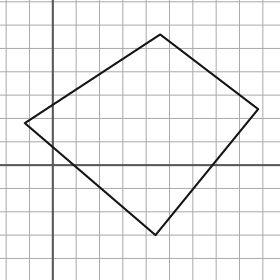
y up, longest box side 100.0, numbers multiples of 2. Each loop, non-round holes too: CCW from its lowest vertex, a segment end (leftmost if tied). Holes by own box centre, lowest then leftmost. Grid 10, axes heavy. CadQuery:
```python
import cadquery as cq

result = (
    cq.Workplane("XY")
    .moveTo(44.0, -30.0)
    .lineTo(88.0, 24.0)
    .lineTo(46.0, 56.0)
    .lineTo(-12.0, 18.0)
    .close()
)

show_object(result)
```